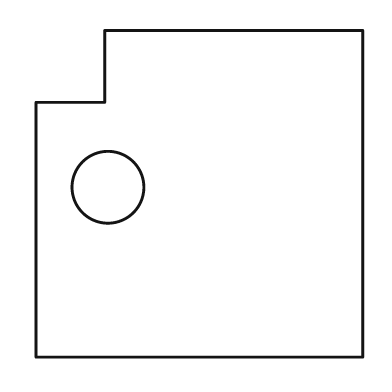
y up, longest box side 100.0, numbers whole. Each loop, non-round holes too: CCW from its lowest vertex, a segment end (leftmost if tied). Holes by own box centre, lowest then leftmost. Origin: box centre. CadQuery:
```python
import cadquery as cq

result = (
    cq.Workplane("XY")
    .moveTo(-50.0, -50.0)
    .lineTo(50.0, -50.0)
    .lineTo(50.0, 50.0)
    .lineTo(-29.0, 50.0)
    .lineTo(-29.0, 28.0)
    .lineTo(-50.0, 28.0)
    .close()
    .moveTo(-28.0, 2.0)
    .circle(11.0)
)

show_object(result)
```